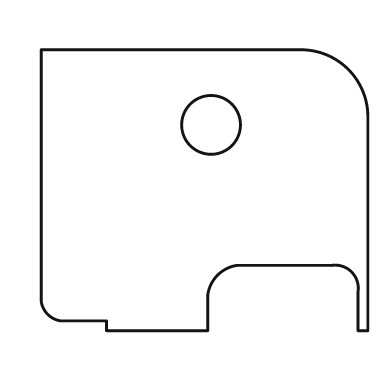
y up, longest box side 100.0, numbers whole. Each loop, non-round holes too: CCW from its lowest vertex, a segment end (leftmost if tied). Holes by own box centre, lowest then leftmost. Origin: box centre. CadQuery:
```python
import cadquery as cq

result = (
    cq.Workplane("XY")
    .moveTo(-30.0, -43.0)
    .lineTo(1.0, -43.0)
    .lineTo(1.0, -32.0)
    .threePointArc((4.0, -26.0), (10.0, -23.0))
    .lineTo(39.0, -23.0)
    .threePointArc((45.0, -25.0), (47.0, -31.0))
    .lineTo(47.0, -43.0)
    .lineTo(50.0, -43.0)
    .lineTo(50.0, 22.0)
    .threePointArc((44.0, 37.0), (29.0, 43.0))
    .lineTo(-50.0, 43.0)
    .lineTo(-50.0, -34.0)
    .threePointArc((-48.0, -38.0), (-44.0, -40.0))
    .lineTo(-30.0, -40.0)
    .close()
    .moveTo(2.0, 20.0)
    .circle(9.0)
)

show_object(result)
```